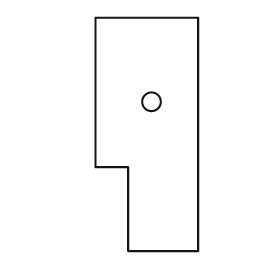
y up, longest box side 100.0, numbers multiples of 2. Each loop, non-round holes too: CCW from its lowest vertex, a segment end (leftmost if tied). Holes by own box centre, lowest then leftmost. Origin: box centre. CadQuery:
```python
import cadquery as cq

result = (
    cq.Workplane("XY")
    .moveTo(-8.0, -50.0)
    .lineTo(22.0, -50.0)
    .lineTo(22.0, 50.0)
    .lineTo(-22.0, 50.0)
    .lineTo(-22.0, -14.0)
    .lineTo(-8.0, -14.0)
    .close()
    .moveTo(2.0, 14.0)
    .circle(4.0)
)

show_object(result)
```